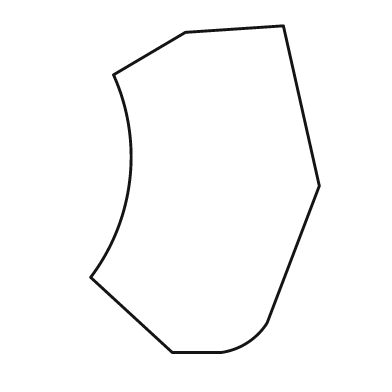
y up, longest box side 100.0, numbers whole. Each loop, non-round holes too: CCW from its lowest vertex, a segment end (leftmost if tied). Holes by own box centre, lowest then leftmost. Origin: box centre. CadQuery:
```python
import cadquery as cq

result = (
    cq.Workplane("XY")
    .moveTo(-10.0, -50.0)
    .lineTo(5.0, -50.0)
    .threePointArc((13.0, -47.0), (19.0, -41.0))
    .lineTo(35.0, 1.0)
    .lineTo(24.0, 50.0)
    .lineTo(-6.0, 48.0)
    .lineTo(-28.0, 35.0)
    .threePointArc((-23.0, 3.0), (-35.0, -27.0))
    .close()
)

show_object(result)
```